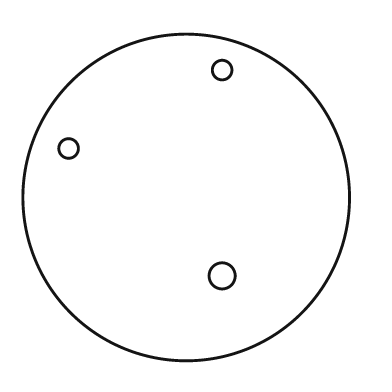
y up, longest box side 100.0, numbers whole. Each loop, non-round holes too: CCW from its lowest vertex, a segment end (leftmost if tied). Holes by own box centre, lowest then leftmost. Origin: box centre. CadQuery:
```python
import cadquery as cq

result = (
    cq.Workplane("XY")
    .moveTo(0.0, 0.0)
    .circle(50.0)
    .moveTo(11.0, -24.0)
    .circle(4.0)
    .moveTo(-36.0, 15.0)
    .circle(3.0)
    .moveTo(11.0, 39.0)
    .circle(3.0)
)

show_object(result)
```